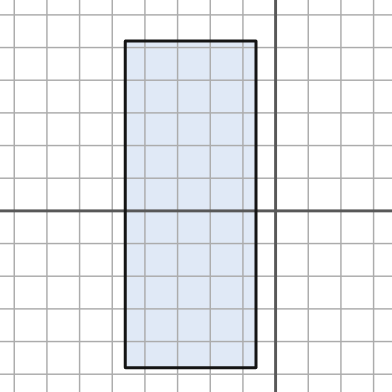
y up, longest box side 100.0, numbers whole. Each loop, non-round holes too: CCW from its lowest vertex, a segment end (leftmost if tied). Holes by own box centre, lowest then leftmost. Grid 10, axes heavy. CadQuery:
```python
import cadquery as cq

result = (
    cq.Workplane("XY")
    .moveTo(-46.0, -48.0)
    .lineTo(-6.0, -48.0)
    .lineTo(-6.0, 52.0)
    .lineTo(-46.0, 52.0)
    .close()
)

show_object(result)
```